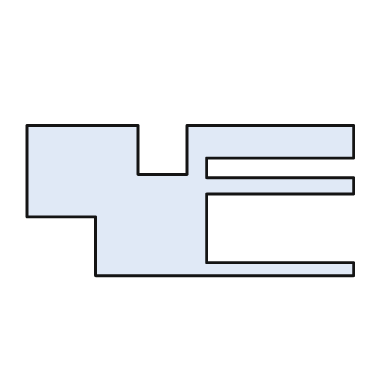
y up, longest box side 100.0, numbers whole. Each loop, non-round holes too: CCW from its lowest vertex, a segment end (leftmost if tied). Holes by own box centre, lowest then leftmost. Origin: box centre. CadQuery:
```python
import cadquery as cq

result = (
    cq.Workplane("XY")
    .moveTo(-29.0, -23.0)
    .lineTo(50.0, -23.0)
    .lineTo(50.0, -19.0)
    .lineTo(5.0, -19.0)
    .lineTo(5.0, 2.0)
    .lineTo(50.0, 2.0)
    .lineTo(50.0, 7.0)
    .lineTo(5.0, 7.0)
    .lineTo(5.0, 13.0)
    .lineTo(50.0, 13.0)
    .lineTo(50.0, 23.0)
    .lineTo(-1.0, 23.0)
    .lineTo(-1.0, 8.0)
    .lineTo(-16.0, 8.0)
    .lineTo(-16.0, 23.0)
    .lineTo(-50.0, 23.0)
    .lineTo(-50.0, -5.0)
    .lineTo(-29.0, -5.0)
    .close()
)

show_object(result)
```